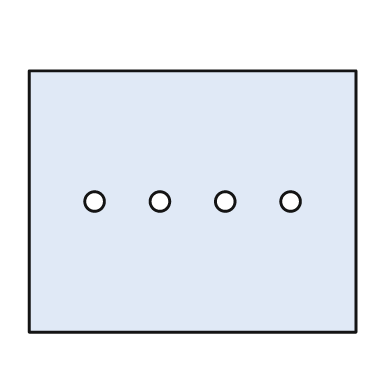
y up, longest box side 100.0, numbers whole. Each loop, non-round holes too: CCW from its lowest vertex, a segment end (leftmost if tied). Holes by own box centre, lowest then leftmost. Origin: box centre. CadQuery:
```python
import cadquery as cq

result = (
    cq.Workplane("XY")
    .moveTo(-50.0, -40.0)
    .lineTo(50.0, -40.0)
    .lineTo(50.0, 40.0)
    .lineTo(-50.0, 40.0)
    .close()
    .moveTo(-30.0, 0.0)
    .circle(3.0)
    .moveTo(-10.0, 0.0)
    .circle(3.0)
    .moveTo(10.0, 0.0)
    .circle(3.0)
    .moveTo(30.0, 0.0)
    .circle(3.0)
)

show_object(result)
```